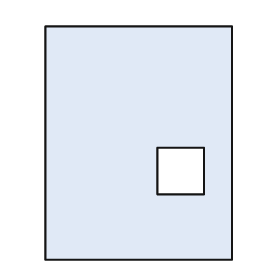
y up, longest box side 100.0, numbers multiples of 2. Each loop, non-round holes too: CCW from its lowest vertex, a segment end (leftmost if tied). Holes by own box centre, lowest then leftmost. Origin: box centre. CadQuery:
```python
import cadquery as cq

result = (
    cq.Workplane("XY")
    .moveTo(-40.0, -50.0)
    .lineTo(40.0, -50.0)
    .lineTo(40.0, 50.0)
    .lineTo(-40.0, 50.0)
    .close()
    .moveTo(8.0, -22.0)
    .lineTo(28.0, -22.0)
    .lineTo(28.0, -2.0)
    .lineTo(8.0, -2.0)
    .close()
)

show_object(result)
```